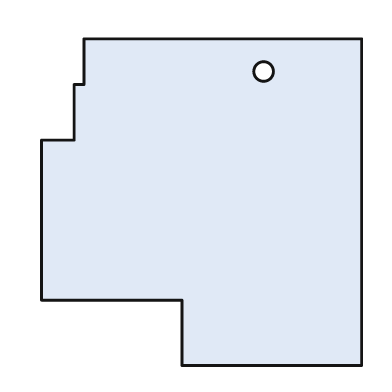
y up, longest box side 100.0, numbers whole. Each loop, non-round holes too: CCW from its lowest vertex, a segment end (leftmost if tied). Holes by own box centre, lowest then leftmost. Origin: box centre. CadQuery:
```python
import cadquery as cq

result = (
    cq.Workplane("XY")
    .moveTo(-6.0, -50.0)
    .lineTo(49.0, -50.0)
    .lineTo(49.0, 50.0)
    .lineTo(-36.0, 50.0)
    .lineTo(-36.0, 36.0)
    .lineTo(-39.0, 36.0)
    .lineTo(-39.0, 19.0)
    .lineTo(-49.0, 19.0)
    .lineTo(-49.0, -30.0)
    .lineTo(-6.0, -30.0)
    .close()
    .moveTo(19.0, 40.0)
    .circle(3.0)
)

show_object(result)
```